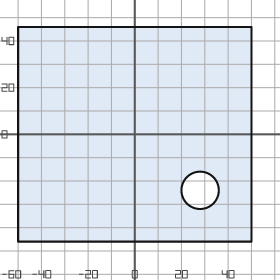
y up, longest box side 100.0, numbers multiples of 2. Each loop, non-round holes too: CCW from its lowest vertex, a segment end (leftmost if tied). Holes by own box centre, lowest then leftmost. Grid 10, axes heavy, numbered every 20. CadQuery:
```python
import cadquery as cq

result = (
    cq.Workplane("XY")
    .moveTo(-50.0, -46.0)
    .lineTo(50.0, -46.0)
    .lineTo(50.0, 46.0)
    .lineTo(-50.0, 46.0)
    .close()
    .moveTo(28.0, -24.0)
    .circle(8.0)
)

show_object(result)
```